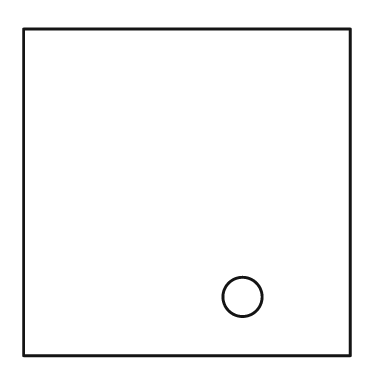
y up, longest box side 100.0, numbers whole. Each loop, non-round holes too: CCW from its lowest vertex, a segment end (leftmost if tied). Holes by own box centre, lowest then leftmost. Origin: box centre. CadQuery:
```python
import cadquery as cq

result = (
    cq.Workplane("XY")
    .moveTo(-50.0, -50.0)
    .lineTo(50.0, -50.0)
    .lineTo(50.0, 50.0)
    .lineTo(-50.0, 50.0)
    .close()
    .moveTo(17.0, -32.0)
    .circle(6.0)
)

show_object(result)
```